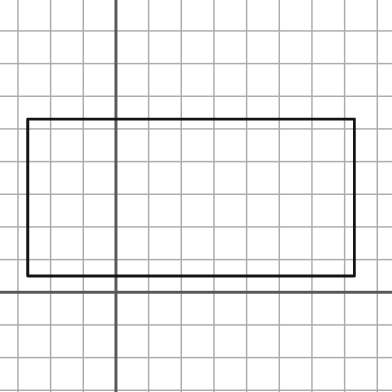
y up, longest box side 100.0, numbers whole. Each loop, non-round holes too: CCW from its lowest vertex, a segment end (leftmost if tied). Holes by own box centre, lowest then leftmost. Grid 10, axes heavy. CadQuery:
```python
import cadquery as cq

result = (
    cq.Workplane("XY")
    .moveTo(-27.0, 5.0)
    .lineTo(73.0, 5.0)
    .lineTo(73.0, 53.0)
    .lineTo(-27.0, 53.0)
    .close()
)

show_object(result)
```